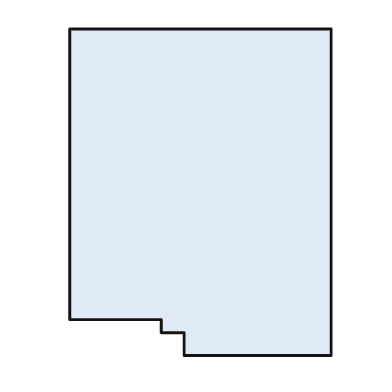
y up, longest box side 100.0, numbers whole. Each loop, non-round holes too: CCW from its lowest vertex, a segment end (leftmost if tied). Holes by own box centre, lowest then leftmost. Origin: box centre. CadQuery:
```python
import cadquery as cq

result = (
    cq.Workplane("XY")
    .moveTo(-5.0, -50.0)
    .lineTo(40.0, -50.0)
    .lineTo(40.0, 50.0)
    .lineTo(-40.0, 50.0)
    .lineTo(-40.0, -39.0)
    .lineTo(-12.0, -39.0)
    .lineTo(-12.0, -43.0)
    .lineTo(-5.0, -43.0)
    .close()
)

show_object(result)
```